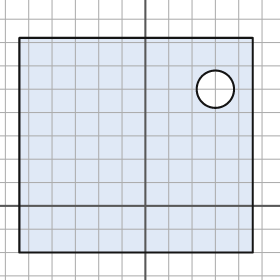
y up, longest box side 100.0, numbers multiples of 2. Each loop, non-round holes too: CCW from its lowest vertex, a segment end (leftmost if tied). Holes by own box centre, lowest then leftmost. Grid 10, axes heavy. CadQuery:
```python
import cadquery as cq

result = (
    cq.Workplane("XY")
    .moveTo(-54.0, -20.0)
    .lineTo(46.0, -20.0)
    .lineTo(46.0, 72.0)
    .lineTo(-54.0, 72.0)
    .close()
    .moveTo(30.0, 50.0)
    .circle(8.0)
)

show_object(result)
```